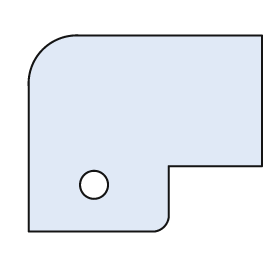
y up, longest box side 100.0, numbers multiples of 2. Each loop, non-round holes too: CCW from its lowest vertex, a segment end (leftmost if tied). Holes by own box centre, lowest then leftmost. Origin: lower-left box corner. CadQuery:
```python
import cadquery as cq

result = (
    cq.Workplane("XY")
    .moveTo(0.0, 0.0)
    .lineTo(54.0, 0.0)
    .threePointArc((58.0, 2.0), (60.0, 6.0))
    .lineTo(60.0, 28.0)
    .lineTo(100.0, 28.0)
    .lineTo(100.0, 84.0)
    .lineTo(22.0, 84.0)
    .threePointArc((6.0, 78.0), (0.0, 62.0))
    .close()
    .moveTo(28.0, 20.0)
    .circle(6.0)
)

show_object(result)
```